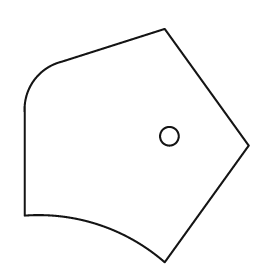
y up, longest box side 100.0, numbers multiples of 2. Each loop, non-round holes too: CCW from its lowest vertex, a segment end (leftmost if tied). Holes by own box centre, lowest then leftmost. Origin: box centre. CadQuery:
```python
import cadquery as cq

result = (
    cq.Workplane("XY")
    .moveTo(12.0, -50.0)
    .lineTo(48.0, 0.0)
    .lineTo(12.0, 50.0)
    .lineTo(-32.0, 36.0)
    .threePointArc((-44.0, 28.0), (-48.0, 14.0))
    .lineTo(-48.0, -30.0)
    .threePointArc((-16.0, -34.0), (12.0, -50.0))
    .close()
    .moveTo(14.0, 4.0)
    .circle(4.0)
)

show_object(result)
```